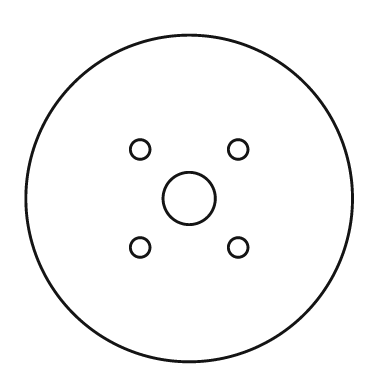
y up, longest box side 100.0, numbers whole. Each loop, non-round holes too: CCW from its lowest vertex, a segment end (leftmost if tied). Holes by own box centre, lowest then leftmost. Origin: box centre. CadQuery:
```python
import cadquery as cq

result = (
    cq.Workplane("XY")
    .moveTo(0.0, 0.0)
    .circle(50.0)
    .moveTo(-15.0, -15.0)
    .circle(3.0)
    .moveTo(15.0, -15.0)
    .circle(3.0)
    .moveTo(0.0, 0.0)
    .circle(8.0)
    .moveTo(-15.0, 15.0)
    .circle(3.0)
    .moveTo(15.0, 15.0)
    .circle(3.0)
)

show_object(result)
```